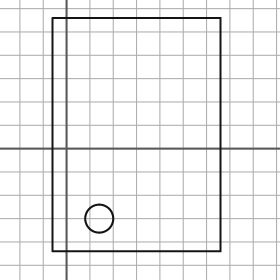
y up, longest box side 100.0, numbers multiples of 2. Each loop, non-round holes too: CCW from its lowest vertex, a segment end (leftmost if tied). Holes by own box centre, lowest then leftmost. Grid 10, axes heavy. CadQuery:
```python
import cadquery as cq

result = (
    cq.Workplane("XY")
    .moveTo(-6.0, -44.0)
    .lineTo(66.0, -44.0)
    .lineTo(66.0, 56.0)
    .lineTo(-6.0, 56.0)
    .close()
    .moveTo(14.0, -30.0)
    .circle(6.0)
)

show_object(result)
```